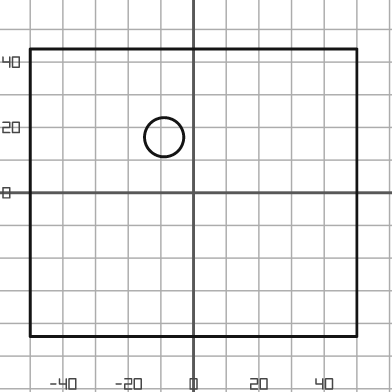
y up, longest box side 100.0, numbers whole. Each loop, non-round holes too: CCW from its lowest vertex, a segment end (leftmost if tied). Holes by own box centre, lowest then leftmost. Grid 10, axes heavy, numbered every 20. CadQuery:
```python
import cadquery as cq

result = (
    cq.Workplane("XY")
    .moveTo(-50.0, -44.0)
    .lineTo(50.0, -44.0)
    .lineTo(50.0, 44.0)
    .lineTo(-50.0, 44.0)
    .close()
    .moveTo(-9.0, 17.0)
    .circle(6.0)
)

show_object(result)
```